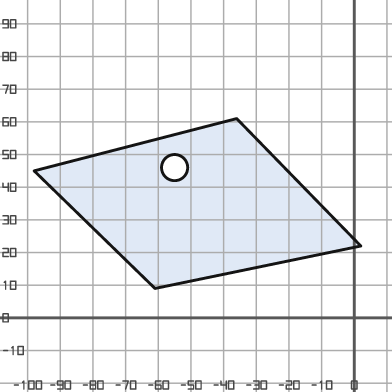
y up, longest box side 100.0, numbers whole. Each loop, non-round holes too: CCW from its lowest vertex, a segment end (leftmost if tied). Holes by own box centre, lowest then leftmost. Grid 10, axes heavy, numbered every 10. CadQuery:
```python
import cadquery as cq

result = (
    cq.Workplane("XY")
    .moveTo(-61.0, 9.0)
    .lineTo(2.0, 22.0)
    .lineTo(-36.0, 61.0)
    .lineTo(-98.0, 45.0)
    .close()
    .moveTo(-55.0, 46.0)
    .circle(4.0)
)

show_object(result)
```